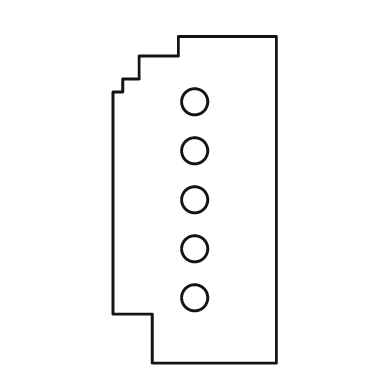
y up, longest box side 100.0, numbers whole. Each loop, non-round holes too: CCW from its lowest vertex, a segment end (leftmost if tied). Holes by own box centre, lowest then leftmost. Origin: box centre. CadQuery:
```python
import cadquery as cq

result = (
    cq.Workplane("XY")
    .moveTo(-13.0, -50.0)
    .lineTo(25.0, -50.0)
    .lineTo(25.0, 50.0)
    .lineTo(-5.0, 50.0)
    .lineTo(-5.0, 44.0)
    .lineTo(-17.0, 44.0)
    .lineTo(-17.0, 37.0)
    .lineTo(-22.0, 37.0)
    .lineTo(-22.0, 33.0)
    .lineTo(-25.0, 33.0)
    .lineTo(-25.0, -35.0)
    .lineTo(-13.0, -35.0)
    .close()
    .moveTo(0.0, -30.0)
    .circle(4.0)
    .moveTo(0.0, -15.0)
    .circle(4.0)
    .moveTo(0.0, 0.0)
    .circle(4.0)
    .moveTo(0.0, 15.0)
    .circle(4.0)
    .moveTo(0.0, 30.0)
    .circle(4.0)
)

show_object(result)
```